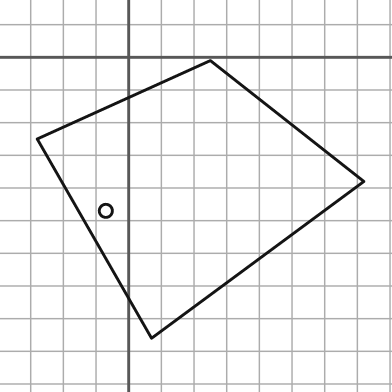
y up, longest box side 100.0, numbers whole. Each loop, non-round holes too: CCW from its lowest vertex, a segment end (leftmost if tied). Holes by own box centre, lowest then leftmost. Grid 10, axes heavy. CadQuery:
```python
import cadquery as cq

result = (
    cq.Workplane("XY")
    .moveTo(7.0, -86.0)
    .lineTo(72.0, -38.0)
    .lineTo(25.0, -1.0)
    .lineTo(-28.0, -25.0)
    .close()
    .moveTo(-7.0, -47.0)
    .circle(2.0)
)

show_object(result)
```